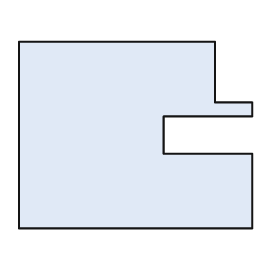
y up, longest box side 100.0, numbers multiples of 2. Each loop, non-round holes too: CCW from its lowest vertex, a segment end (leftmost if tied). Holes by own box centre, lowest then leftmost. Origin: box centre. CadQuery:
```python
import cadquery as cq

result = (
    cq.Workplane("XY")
    .moveTo(-50.0, -40.0)
    .lineTo(50.0, -40.0)
    .lineTo(50.0, -8.0)
    .lineTo(12.0, -8.0)
    .lineTo(12.0, 8.0)
    .lineTo(50.0, 8.0)
    .lineTo(50.0, 14.0)
    .lineTo(34.0, 14.0)
    .lineTo(34.0, 40.0)
    .lineTo(-50.0, 40.0)
    .close()
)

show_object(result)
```